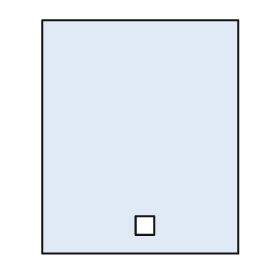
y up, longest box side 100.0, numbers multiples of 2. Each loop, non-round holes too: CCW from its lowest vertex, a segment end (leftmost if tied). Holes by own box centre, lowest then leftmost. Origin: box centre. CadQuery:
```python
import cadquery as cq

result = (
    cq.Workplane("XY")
    .moveTo(-42.0, -50.0)
    .lineTo(42.0, -50.0)
    .lineTo(42.0, 50.0)
    .lineTo(-42.0, 50.0)
    .close()
    .moveTo(-2.0, -42.0)
    .lineTo(6.0, -42.0)
    .lineTo(6.0, -34.0)
    .lineTo(-2.0, -34.0)
    .close()
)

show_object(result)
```